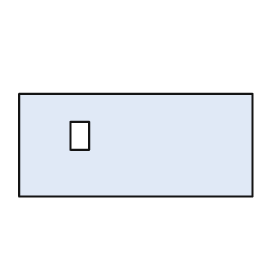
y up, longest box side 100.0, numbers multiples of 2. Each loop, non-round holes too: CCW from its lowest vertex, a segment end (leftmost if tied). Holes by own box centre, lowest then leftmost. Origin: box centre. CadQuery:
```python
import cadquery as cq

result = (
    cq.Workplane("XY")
    .moveTo(-50.0, -22.0)
    .lineTo(50.0, -22.0)
    .lineTo(50.0, 22.0)
    .lineTo(-50.0, 22.0)
    .close()
    .moveTo(-28.0, -2.0)
    .lineTo(-20.0, -2.0)
    .lineTo(-20.0, 10.0)
    .lineTo(-28.0, 10.0)
    .close()
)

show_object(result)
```